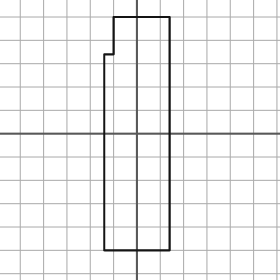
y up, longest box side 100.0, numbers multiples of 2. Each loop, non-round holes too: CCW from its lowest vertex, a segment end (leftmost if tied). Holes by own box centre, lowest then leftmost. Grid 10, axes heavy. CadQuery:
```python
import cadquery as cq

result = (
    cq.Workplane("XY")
    .moveTo(-14.0, -50.0)
    .lineTo(14.0, -50.0)
    .lineTo(14.0, 50.0)
    .lineTo(-10.0, 50.0)
    .lineTo(-10.0, 34.0)
    .lineTo(-14.0, 34.0)
    .close()
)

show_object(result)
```